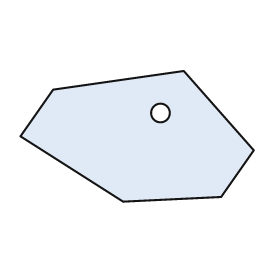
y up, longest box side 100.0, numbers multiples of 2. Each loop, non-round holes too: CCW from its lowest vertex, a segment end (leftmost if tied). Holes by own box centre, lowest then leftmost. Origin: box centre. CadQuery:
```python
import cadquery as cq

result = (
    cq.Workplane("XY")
    .moveTo(-6.0, -28.0)
    .lineTo(36.0, -26.0)
    .lineTo(50.0, -6.0)
    .lineTo(20.0, 28.0)
    .lineTo(-36.0, 20.0)
    .lineTo(-50.0, 0.0)
    .close()
    .moveTo(10.0, 10.0)
    .circle(4.0)
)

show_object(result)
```